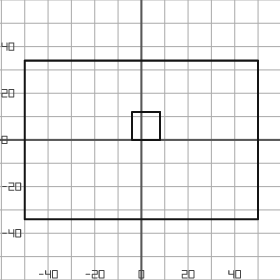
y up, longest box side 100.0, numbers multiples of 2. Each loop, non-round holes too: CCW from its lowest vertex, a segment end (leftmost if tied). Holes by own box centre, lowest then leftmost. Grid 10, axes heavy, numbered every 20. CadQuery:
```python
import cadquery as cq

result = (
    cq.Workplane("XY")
    .moveTo(-50.0, -34.0)
    .lineTo(50.0, -34.0)
    .lineTo(50.0, 34.0)
    .lineTo(-50.0, 34.0)
    .close()
    .moveTo(-4.0, 0.0)
    .lineTo(8.0, 0.0)
    .lineTo(8.0, 12.0)
    .lineTo(-4.0, 12.0)
    .close()
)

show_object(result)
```